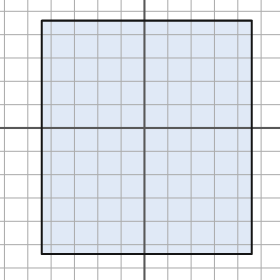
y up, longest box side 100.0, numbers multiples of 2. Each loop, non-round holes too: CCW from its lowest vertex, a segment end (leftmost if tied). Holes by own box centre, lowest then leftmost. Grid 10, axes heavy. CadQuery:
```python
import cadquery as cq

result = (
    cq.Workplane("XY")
    .moveTo(-44.0, -54.0)
    .lineTo(46.0, -54.0)
    .lineTo(46.0, 46.0)
    .lineTo(-44.0, 46.0)
    .close()
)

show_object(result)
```